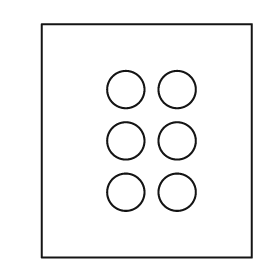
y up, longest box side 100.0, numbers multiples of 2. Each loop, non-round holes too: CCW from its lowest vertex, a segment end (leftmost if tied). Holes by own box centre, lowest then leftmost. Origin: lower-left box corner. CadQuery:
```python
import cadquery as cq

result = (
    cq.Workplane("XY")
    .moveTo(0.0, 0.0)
    .lineTo(90.0, 0.0)
    .lineTo(90.0, 100.0)
    .lineTo(0.0, 100.0)
    .close()
    .moveTo(36.0, 28.0)
    .circle(8.0)
    .moveTo(58.0, 28.0)
    .circle(8.0)
    .moveTo(36.0, 50.0)
    .circle(8.0)
    .moveTo(58.0, 50.0)
    .circle(8.0)
    .moveTo(36.0, 72.0)
    .circle(8.0)
    .moveTo(58.0, 72.0)
    .circle(8.0)
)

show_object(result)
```